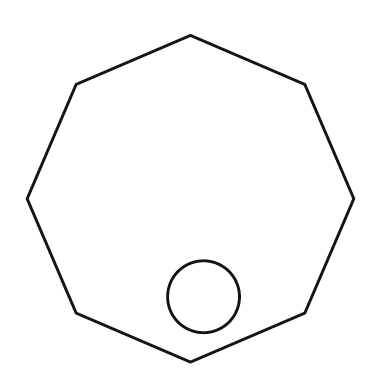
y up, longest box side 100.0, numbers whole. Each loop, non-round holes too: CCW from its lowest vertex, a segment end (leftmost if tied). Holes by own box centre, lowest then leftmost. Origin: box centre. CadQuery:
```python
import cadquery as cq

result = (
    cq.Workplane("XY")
    .moveTo(0.0, -50.0)
    .lineTo(35.0, -35.0)
    .lineTo(50.0, 0.0)
    .lineTo(35.0, 35.0)
    .lineTo(0.0, 50.0)
    .lineTo(-35.0, 35.0)
    .lineTo(-50.0, 0.0)
    .lineTo(-35.0, -35.0)
    .close()
    .moveTo(4.0, -30.0)
    .circle(11.0)
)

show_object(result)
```